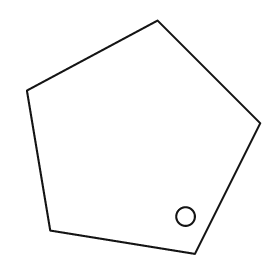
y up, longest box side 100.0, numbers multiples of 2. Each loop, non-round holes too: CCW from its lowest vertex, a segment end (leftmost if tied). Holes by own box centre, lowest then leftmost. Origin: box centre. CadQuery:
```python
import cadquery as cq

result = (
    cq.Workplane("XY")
    .moveTo(22.0, -50.0)
    .lineTo(50.0, 6.0)
    .lineTo(6.0, 50.0)
    .lineTo(-50.0, 20.0)
    .lineTo(-40.0, -40.0)
    .close()
    .moveTo(18.0, -34.0)
    .circle(4.0)
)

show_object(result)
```